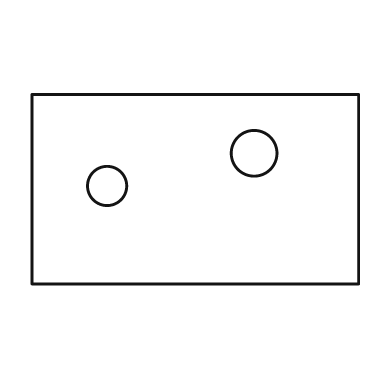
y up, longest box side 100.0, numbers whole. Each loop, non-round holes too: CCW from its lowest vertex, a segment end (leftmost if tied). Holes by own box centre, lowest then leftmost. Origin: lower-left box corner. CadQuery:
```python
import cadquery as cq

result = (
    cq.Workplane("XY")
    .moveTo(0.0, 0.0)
    .lineTo(100.0, 0.0)
    .lineTo(100.0, 58.0)
    .lineTo(0.0, 58.0)
    .close()
    .moveTo(23.0, 30.0)
    .circle(6.0)
    .moveTo(68.0, 40.0)
    .circle(7.0)
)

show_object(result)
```